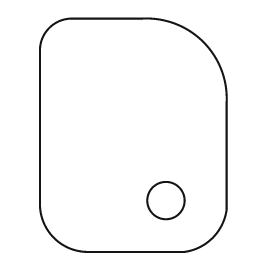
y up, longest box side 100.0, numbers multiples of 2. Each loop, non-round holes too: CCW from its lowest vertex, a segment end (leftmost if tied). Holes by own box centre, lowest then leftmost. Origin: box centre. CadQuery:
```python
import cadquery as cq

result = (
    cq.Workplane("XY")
    .moveTo(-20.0, -50.0)
    .lineTo(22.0, -50.0)
    .threePointArc((34.0, -44.0), (40.0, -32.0))
    .lineTo(40.0, 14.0)
    .threePointArc((30.0, 40.0), (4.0, 50.0))
    .lineTo(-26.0, 50.0)
    .threePointArc((-36.0, 46.0), (-40.0, 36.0))
    .lineTo(-40.0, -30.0)
    .threePointArc((-34.0, -44.0), (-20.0, -50.0))
    .close()
    .moveTo(14.0, -28.0)
    .circle(8.0)
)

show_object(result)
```